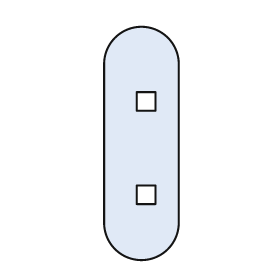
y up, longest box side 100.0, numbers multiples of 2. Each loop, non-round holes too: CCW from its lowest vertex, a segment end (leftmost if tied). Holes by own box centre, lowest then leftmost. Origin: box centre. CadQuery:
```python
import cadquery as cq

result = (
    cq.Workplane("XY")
    .moveTo(-16.0, -34.0)
    .threePointArc((0.0, -50.0), (16.0, -34.0))
    .lineTo(16.0, 34.0)
    .threePointArc((0.0, 50.0), (-16.0, 34.0))
    .close()
    .moveTo(-2.0, -26.0)
    .lineTo(6.0, -26.0)
    .lineTo(6.0, -18.0)
    .lineTo(-2.0, -18.0)
    .close()
    .moveTo(-2.0, 14.0)
    .lineTo(6.0, 14.0)
    .lineTo(6.0, 22.0)
    .lineTo(-2.0, 22.0)
    .close()
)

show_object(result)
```